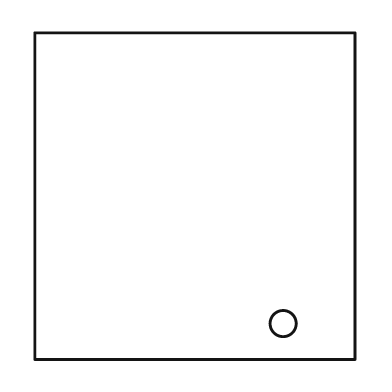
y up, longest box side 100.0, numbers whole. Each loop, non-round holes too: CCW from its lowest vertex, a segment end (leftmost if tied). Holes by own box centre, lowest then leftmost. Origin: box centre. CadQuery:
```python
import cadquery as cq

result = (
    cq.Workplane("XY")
    .moveTo(-49.0, -50.0)
    .lineTo(49.0, -50.0)
    .lineTo(49.0, 50.0)
    .lineTo(-49.0, 50.0)
    .close()
    .moveTo(27.0, -39.0)
    .circle(4.0)
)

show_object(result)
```